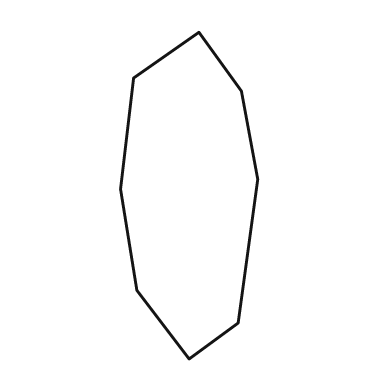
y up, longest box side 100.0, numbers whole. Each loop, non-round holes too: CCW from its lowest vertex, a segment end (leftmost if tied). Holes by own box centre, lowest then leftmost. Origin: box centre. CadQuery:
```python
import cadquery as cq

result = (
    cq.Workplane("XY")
    .moveTo(0.0, -50.0)
    .lineTo(15.0, -39.0)
    .lineTo(21.0, 5.0)
    .lineTo(16.0, 32.0)
    .lineTo(3.0, 50.0)
    .lineTo(-17.0, 36.0)
    .lineTo(-21.0, 2.0)
    .lineTo(-16.0, -29.0)
    .close()
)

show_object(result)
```